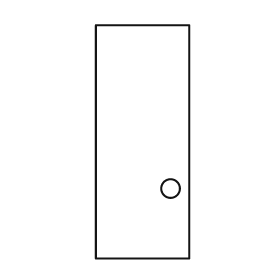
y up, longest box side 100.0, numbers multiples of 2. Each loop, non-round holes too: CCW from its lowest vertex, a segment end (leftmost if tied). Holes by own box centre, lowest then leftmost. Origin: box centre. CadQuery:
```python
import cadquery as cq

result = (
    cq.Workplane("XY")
    .moveTo(-20.0, -50.0)
    .lineTo(20.0, -50.0)
    .lineTo(20.0, 50.0)
    .lineTo(-20.0, 50.0)
    .close()
    .moveTo(12.0, -20.0)
    .circle(4.0)
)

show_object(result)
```